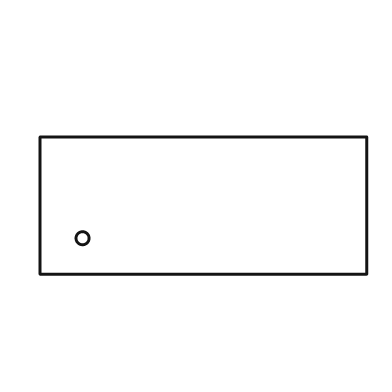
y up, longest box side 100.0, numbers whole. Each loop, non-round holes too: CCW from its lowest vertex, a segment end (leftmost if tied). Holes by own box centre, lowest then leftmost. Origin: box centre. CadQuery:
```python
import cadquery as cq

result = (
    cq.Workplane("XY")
    .moveTo(-50.0, -21.0)
    .lineTo(50.0, -21.0)
    .lineTo(50.0, 21.0)
    .lineTo(-50.0, 21.0)
    .close()
    .moveTo(-37.0, -10.0)
    .circle(2.0)
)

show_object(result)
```